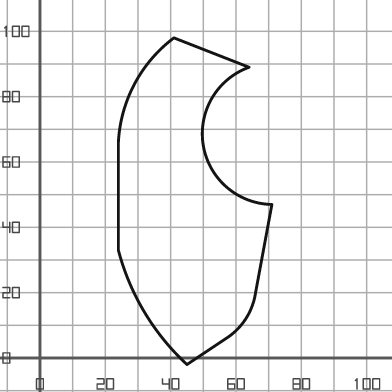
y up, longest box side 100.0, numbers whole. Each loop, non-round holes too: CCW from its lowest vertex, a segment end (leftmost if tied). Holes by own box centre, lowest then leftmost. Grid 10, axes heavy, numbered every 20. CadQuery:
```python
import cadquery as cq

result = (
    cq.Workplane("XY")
    .moveTo(45.0, -2.0)
    .lineTo(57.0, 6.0)
    .threePointArc((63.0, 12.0), (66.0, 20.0))
    .lineTo(71.0, 47.0)
    .threePointArc((50.0, 65.0), (64.0, 89.0))
    .lineTo(41.0, 98.0)
    .threePointArc((29.0, 84.0), (24.0, 66.0))
    .lineTo(24.0, 33.0)
    .threePointArc((32.0, 14.0), (45.0, -2.0))
    .close()
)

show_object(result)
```